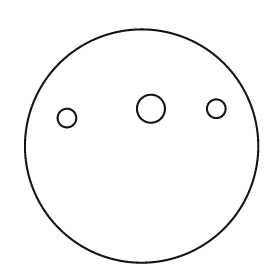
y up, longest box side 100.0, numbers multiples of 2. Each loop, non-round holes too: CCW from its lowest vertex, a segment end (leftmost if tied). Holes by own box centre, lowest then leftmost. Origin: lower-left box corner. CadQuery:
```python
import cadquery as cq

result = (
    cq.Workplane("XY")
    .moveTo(50.0, 50.0)
    .circle(50.0)
    .moveTo(18.0, 62.0)
    .circle(4.0)
    .moveTo(54.0, 66.0)
    .circle(6.0)
    .moveTo(82.0, 66.0)
    .circle(4.0)
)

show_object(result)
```